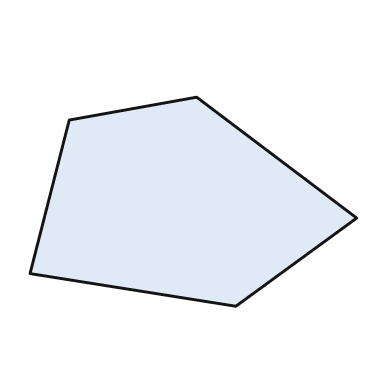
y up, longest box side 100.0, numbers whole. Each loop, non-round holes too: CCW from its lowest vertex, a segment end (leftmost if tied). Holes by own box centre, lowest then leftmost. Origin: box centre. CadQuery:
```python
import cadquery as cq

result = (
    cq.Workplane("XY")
    .moveTo(13.0, -32.0)
    .lineTo(50.0, -5.0)
    .lineTo(1.0, 32.0)
    .lineTo(-38.0, 25.0)
    .lineTo(-50.0, -22.0)
    .close()
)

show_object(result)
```